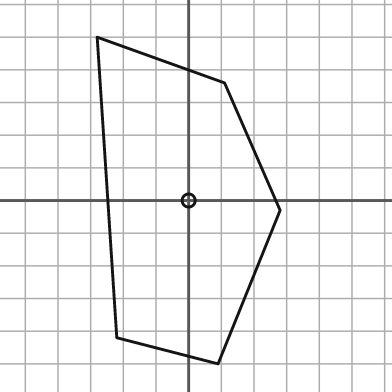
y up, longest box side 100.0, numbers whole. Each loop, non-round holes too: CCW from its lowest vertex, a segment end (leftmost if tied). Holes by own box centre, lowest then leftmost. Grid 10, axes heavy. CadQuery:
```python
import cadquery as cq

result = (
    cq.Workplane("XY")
    .moveTo(9.0, -50.0)
    .lineTo(28.0, -3.0)
    .lineTo(11.0, 36.0)
    .lineTo(-28.0, 50.0)
    .lineTo(-22.0, -42.0)
    .close()
    .moveTo(0.0, 0.0)
    .circle(2.0)
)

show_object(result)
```